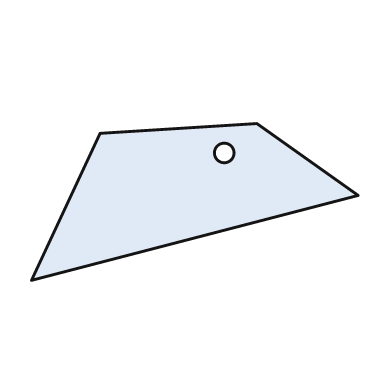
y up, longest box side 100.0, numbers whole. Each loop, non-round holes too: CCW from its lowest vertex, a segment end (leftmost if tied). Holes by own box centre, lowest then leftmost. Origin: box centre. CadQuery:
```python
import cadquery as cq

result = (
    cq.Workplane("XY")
    .moveTo(-50.0, -24.0)
    .lineTo(50.0, 2.0)
    .lineTo(19.0, 24.0)
    .lineTo(-29.0, 21.0)
    .close()
    .moveTo(9.0, 15.0)
    .circle(3.0)
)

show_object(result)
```